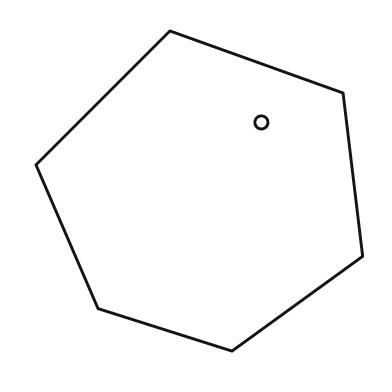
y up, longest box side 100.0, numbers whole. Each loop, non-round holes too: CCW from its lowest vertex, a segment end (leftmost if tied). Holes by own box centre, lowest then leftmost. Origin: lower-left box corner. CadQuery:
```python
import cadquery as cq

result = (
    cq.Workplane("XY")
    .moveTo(60.0, 0.0)
    .lineTo(100.0, 29.0)
    .lineTo(94.0, 79.0)
    .lineTo(41.0, 98.0)
    .lineTo(0.0, 57.0)
    .lineTo(19.0, 13.0)
    .close()
    .moveTo(69.0, 70.0)
    .circle(2.0)
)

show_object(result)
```